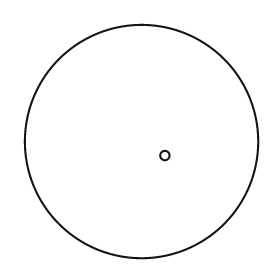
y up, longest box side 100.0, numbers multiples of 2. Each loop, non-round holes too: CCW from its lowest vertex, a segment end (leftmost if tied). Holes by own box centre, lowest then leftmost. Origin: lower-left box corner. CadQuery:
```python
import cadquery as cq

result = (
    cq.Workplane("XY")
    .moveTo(50.0, 50.0)
    .circle(50.0)
    .moveTo(60.0, 44.0)
    .circle(2.0)
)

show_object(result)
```